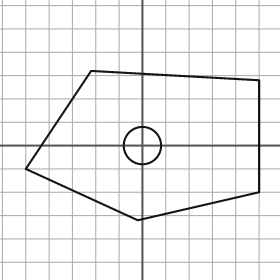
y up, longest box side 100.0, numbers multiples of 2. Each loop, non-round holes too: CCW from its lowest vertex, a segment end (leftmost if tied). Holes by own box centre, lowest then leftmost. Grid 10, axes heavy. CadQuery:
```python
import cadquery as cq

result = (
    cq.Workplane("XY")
    .moveTo(-2.0, -32.0)
    .lineTo(50.0, -20.0)
    .lineTo(50.0, 28.0)
    .lineTo(-22.0, 32.0)
    .lineTo(-50.0, -10.0)
    .close()
    .moveTo(0.0, 0.0)
    .circle(8.0)
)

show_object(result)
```